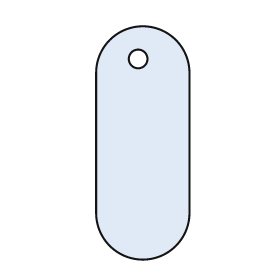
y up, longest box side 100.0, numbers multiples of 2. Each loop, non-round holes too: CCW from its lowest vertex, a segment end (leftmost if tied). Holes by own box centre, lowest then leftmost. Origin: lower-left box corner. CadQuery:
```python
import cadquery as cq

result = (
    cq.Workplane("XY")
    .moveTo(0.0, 20.0)
    .threePointArc((20.0, 0.0), (40.0, 20.0))
    .lineTo(40.0, 80.0)
    .threePointArc((20.0, 100.0), (0.0, 80.0))
    .close()
    .moveTo(18.0, 86.0)
    .circle(4.0)
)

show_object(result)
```